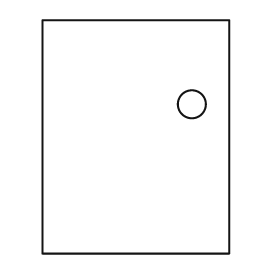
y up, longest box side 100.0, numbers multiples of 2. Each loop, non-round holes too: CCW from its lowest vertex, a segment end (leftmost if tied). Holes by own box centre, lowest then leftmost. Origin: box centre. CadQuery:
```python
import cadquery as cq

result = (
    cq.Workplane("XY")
    .moveTo(-40.0, -50.0)
    .lineTo(40.0, -50.0)
    .lineTo(40.0, 50.0)
    .lineTo(-40.0, 50.0)
    .close()
    .moveTo(24.0, 14.0)
    .circle(6.0)
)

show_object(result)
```